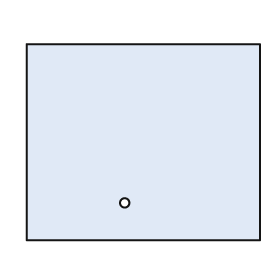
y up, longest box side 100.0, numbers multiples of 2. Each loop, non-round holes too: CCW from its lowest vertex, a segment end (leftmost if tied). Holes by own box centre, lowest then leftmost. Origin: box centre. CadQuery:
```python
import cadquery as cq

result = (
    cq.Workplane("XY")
    .moveTo(-50.0, -42.0)
    .lineTo(50.0, -42.0)
    .lineTo(50.0, 42.0)
    .lineTo(-50.0, 42.0)
    .close()
    .moveTo(-8.0, -26.0)
    .circle(2.0)
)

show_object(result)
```